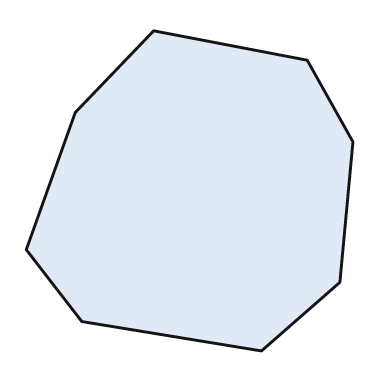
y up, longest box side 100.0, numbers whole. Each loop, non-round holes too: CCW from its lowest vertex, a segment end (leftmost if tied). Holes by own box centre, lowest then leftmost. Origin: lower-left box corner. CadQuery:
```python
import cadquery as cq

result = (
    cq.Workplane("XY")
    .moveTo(72.0, 0.0)
    .lineTo(96.0, 21.0)
    .lineTo(100.0, 64.0)
    .lineTo(86.0, 89.0)
    .lineTo(39.0, 98.0)
    .lineTo(15.0, 73.0)
    .lineTo(0.0, 31.0)
    .lineTo(17.0, 9.0)
    .close()
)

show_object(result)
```